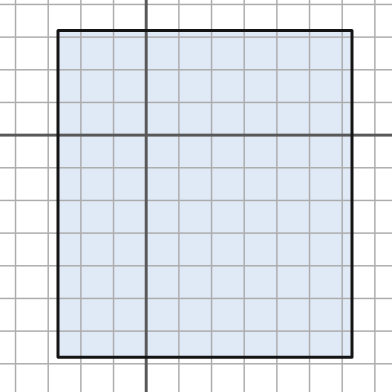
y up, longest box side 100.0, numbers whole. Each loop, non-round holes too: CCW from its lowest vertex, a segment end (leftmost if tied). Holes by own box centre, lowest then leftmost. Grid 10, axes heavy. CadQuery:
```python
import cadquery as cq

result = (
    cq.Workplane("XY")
    .moveTo(-27.0, -68.0)
    .lineTo(63.0, -68.0)
    .lineTo(63.0, 32.0)
    .lineTo(-27.0, 32.0)
    .close()
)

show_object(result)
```